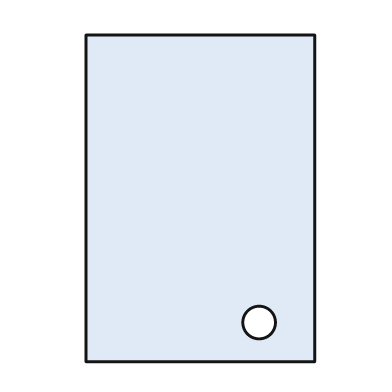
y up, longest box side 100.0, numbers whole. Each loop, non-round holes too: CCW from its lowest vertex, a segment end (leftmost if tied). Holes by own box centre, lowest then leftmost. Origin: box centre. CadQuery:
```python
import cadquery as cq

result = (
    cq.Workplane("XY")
    .moveTo(-35.0, -50.0)
    .lineTo(35.0, -50.0)
    .lineTo(35.0, 50.0)
    .lineTo(-35.0, 50.0)
    .close()
    .moveTo(18.0, -38.0)
    .circle(5.0)
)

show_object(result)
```